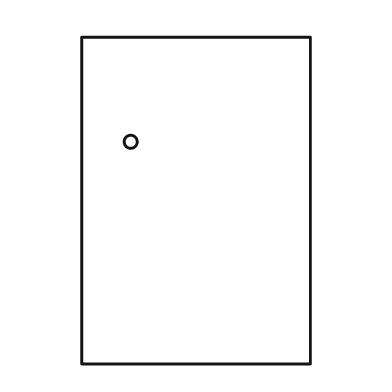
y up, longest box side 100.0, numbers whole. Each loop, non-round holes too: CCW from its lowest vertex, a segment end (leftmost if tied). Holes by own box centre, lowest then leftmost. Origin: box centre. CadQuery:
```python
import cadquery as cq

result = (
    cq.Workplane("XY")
    .moveTo(-35.0, -50.0)
    .lineTo(35.0, -50.0)
    .lineTo(35.0, 50.0)
    .lineTo(-35.0, 50.0)
    .close()
    .moveTo(-20.0, 18.0)
    .circle(2.0)
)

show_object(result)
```